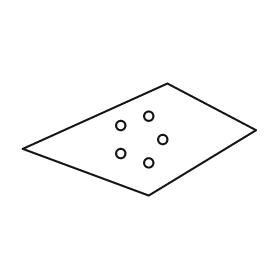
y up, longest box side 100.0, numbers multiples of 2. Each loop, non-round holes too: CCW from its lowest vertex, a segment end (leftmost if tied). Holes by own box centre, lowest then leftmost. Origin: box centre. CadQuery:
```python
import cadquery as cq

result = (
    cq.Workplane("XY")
    .moveTo(4.0, -24.0)
    .lineTo(50.0, 4.0)
    .lineTo(12.0, 24.0)
    .lineTo(-50.0, -4.0)
    .close()
    .moveTo(4.0, -10.0)
    .circle(2.0)
    .moveTo(-8.0, -6.0)
    .circle(2.0)
    .moveTo(10.0, 0.0)
    .circle(2.0)
    .moveTo(-8.0, 6.0)
    .circle(2.0)
    .moveTo(4.0, 10.0)
    .circle(2.0)
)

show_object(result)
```